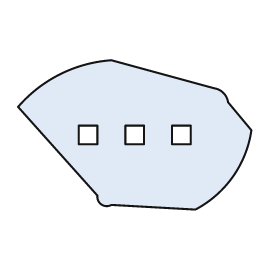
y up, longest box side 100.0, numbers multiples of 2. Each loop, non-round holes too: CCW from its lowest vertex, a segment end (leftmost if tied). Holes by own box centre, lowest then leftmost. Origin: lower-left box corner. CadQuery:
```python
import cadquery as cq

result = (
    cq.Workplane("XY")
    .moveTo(76.0, 0.0)
    .threePointArc((92.0, 14.0), (100.0, 34.0))
    .lineTo(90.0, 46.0)
    .threePointArc((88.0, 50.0), (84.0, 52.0))
    .lineTo(40.0, 64.0)
    .threePointArc((18.0, 58.0), (0.0, 44.0))
    .lineTo(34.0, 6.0)
    .threePointArc((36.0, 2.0), (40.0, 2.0))
    .close()
    .moveTo(26.0, 28.0)
    .lineTo(34.0, 28.0)
    .lineTo(34.0, 36.0)
    .lineTo(26.0, 36.0)
    .close()
    .moveTo(46.0, 28.0)
    .lineTo(54.0, 28.0)
    .lineTo(54.0, 36.0)
    .lineTo(46.0, 36.0)
    .close()
    .moveTo(66.0, 28.0)
    .lineTo(74.0, 28.0)
    .lineTo(74.0, 36.0)
    .lineTo(66.0, 36.0)
    .close()
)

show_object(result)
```